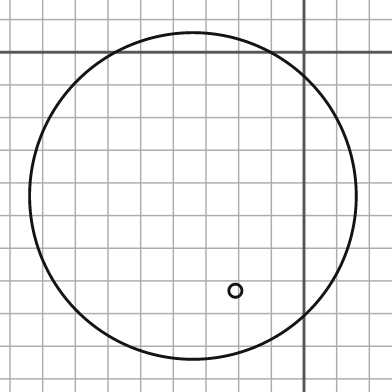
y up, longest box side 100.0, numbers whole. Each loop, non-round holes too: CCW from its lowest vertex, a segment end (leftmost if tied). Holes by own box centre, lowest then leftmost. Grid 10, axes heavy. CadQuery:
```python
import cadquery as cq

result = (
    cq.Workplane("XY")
    .moveTo(-34.0, -44.0)
    .circle(50.0)
    .moveTo(-21.0, -73.0)
    .circle(2.0)
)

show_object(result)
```